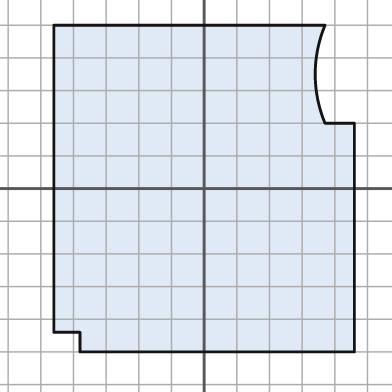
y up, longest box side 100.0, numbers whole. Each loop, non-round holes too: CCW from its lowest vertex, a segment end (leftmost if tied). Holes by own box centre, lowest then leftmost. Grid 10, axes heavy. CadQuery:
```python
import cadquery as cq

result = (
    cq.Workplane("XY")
    .moveTo(-38.0, -50.0)
    .lineTo(46.0, -50.0)
    .lineTo(46.0, 20.0)
    .lineTo(37.0, 20.0)
    .threePointArc((34.0, 35.0), (37.0, 50.0))
    .lineTo(-46.0, 50.0)
    .lineTo(-46.0, -44.0)
    .lineTo(-38.0, -44.0)
    .close()
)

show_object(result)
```